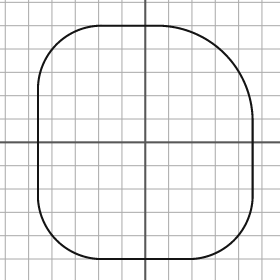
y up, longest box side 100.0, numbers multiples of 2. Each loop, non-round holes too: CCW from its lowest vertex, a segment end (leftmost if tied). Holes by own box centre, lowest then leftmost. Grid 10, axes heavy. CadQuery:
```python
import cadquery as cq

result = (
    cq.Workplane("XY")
    .moveTo(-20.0, -50.0)
    .lineTo(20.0, -50.0)
    .threePointArc((38.0, -42.0), (46.0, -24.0))
    .lineTo(46.0, 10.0)
    .threePointArc((34.0, 38.0), (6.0, 50.0))
    .lineTo(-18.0, 50.0)
    .threePointArc((-38.0, 42.0), (-46.0, 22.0))
    .lineTo(-46.0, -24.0)
    .threePointArc((-38.0, -42.0), (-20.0, -50.0))
    .close()
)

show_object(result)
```